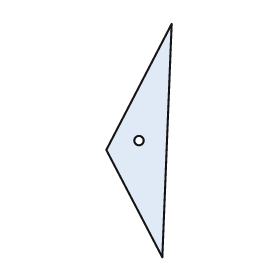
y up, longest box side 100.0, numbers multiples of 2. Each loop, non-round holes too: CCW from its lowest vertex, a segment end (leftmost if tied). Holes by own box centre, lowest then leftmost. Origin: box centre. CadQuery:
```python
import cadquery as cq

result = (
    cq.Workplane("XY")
    .moveTo(10.0, -50.0)
    .lineTo(14.0, 50.0)
    .lineTo(-14.0, -4.0)
    .close()
    .moveTo(0.0, 0.0)
    .circle(2.0)
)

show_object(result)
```